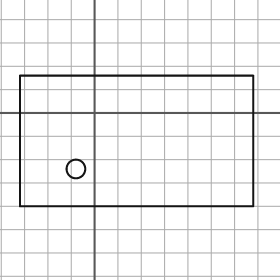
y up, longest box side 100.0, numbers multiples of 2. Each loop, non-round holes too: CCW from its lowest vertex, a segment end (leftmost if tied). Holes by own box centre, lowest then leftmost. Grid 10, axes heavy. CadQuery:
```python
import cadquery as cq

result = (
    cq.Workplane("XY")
    .moveTo(-32.0, -40.0)
    .lineTo(68.0, -40.0)
    .lineTo(68.0, 16.0)
    .lineTo(-32.0, 16.0)
    .close()
    .moveTo(-8.0, -24.0)
    .circle(4.0)
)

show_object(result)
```